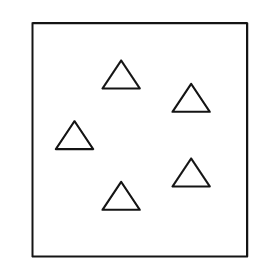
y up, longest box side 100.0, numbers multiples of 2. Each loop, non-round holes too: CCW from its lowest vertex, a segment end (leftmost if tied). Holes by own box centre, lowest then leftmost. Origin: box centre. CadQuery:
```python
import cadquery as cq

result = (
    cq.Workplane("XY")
    .moveTo(-46.0, -50.0)
    .lineTo(46.0, -50.0)
    .lineTo(46.0, 50.0)
    .lineTo(-46.0, 50.0)
    .close()
    .moveTo(-16.0, -30.0)
    .lineTo(0.0, -30.0)
    .lineTo(-8.0, -18.0)
    .close()
    .moveTo(14.0, -20.0)
    .lineTo(30.0, -20.0)
    .lineTo(22.0, -8.0)
    .close()
    .moveTo(-36.0, -4.0)
    .lineTo(-20.0, -4.0)
    .lineTo(-28.0, 8.0)
    .close()
    .moveTo(14.0, 12.0)
    .lineTo(30.0, 12.0)
    .lineTo(22.0, 24.0)
    .close()
    .moveTo(-16.0, 22.0)
    .lineTo(0.0, 22.0)
    .lineTo(-8.0, 34.0)
    .close()
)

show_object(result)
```